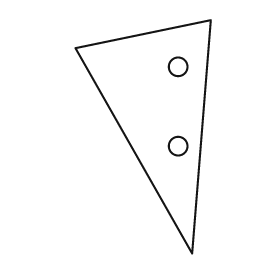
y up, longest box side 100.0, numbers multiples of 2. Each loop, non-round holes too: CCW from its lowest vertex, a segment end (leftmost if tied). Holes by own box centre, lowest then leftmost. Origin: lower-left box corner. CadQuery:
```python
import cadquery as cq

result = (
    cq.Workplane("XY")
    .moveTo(50.0, 0.0)
    .lineTo(58.0, 100.0)
    .lineTo(0.0, 88.0)
    .close()
    .moveTo(44.0, 46.0)
    .circle(4.0)
    .moveTo(44.0, 80.0)
    .circle(4.0)
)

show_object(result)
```